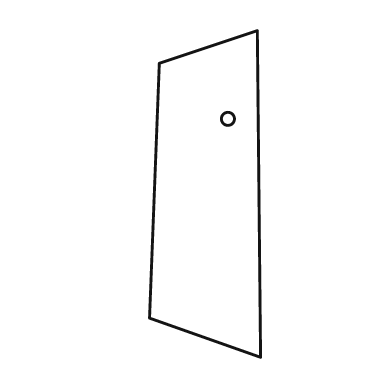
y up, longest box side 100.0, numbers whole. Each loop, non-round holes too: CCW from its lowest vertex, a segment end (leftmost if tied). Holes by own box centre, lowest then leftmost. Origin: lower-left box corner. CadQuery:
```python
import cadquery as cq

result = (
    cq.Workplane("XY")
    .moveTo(34.0, 0.0)
    .lineTo(33.0, 100.0)
    .lineTo(3.0, 90.0)
    .lineTo(0.0, 12.0)
    .close()
    .moveTo(24.0, 73.0)
    .circle(2.0)
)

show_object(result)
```